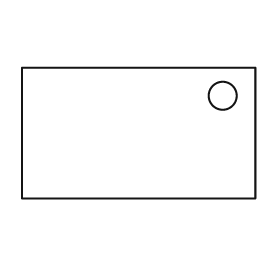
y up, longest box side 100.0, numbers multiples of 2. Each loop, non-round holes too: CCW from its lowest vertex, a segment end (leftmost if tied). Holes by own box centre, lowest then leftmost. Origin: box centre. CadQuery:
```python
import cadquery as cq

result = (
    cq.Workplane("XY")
    .moveTo(-50.0, -28.0)
    .lineTo(50.0, -28.0)
    .lineTo(50.0, 28.0)
    .lineTo(-50.0, 28.0)
    .close()
    .moveTo(36.0, 16.0)
    .circle(6.0)
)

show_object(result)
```